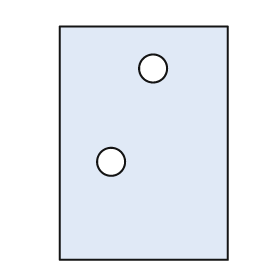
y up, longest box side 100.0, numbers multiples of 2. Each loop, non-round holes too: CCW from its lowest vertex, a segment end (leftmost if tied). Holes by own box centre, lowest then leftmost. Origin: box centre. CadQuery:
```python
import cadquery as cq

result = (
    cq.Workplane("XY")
    .moveTo(-36.0, -50.0)
    .lineTo(36.0, -50.0)
    .lineTo(36.0, 50.0)
    .lineTo(-36.0, 50.0)
    .close()
    .moveTo(-14.0, -8.0)
    .circle(6.0)
    .moveTo(4.0, 32.0)
    .circle(6.0)
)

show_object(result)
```